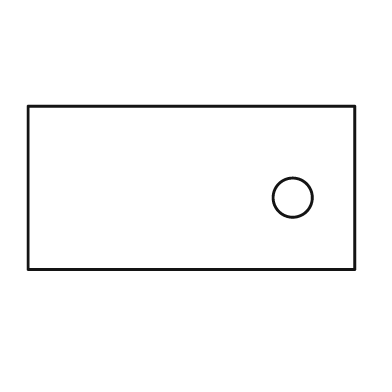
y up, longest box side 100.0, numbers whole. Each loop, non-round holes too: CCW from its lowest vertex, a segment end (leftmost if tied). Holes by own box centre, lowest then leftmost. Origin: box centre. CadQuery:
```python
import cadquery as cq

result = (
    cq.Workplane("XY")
    .moveTo(-50.0, -25.0)
    .lineTo(50.0, -25.0)
    .lineTo(50.0, 25.0)
    .lineTo(-50.0, 25.0)
    .close()
    .moveTo(31.0, -3.0)
    .circle(6.0)
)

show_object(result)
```